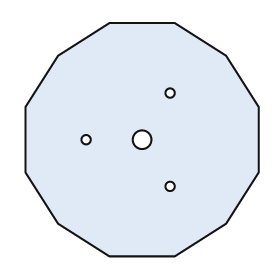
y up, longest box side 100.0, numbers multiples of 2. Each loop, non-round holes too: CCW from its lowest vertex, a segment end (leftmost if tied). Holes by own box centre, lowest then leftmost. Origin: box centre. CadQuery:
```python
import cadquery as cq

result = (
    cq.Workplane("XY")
    .moveTo(-14.0, -50.0)
    .lineTo(14.0, -50.0)
    .lineTo(36.0, -36.0)
    .lineTo(50.0, -14.0)
    .lineTo(50.0, 14.0)
    .lineTo(36.0, 36.0)
    .lineTo(14.0, 50.0)
    .lineTo(-14.0, 50.0)
    .lineTo(-36.0, 36.0)
    .lineTo(-50.0, 14.0)
    .lineTo(-50.0, -14.0)
    .lineTo(-36.0, -36.0)
    .close()
    .moveTo(12.0, -20.0)
    .circle(2.0)
    .moveTo(-24.0, 0.0)
    .circle(2.0)
    .moveTo(0.0, 0.0)
    .circle(4.0)
    .moveTo(12.0, 20.0)
    .circle(2.0)
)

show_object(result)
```